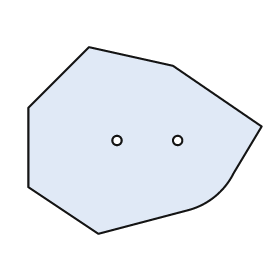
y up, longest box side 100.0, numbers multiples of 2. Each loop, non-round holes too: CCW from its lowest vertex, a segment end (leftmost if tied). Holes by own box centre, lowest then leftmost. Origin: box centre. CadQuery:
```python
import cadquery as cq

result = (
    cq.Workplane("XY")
    .moveTo(-20.0, -40.0)
    .lineTo(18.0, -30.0)
    .threePointArc((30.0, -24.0), (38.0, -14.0))
    .lineTo(50.0, 6.0)
    .lineTo(12.0, 32.0)
    .lineTo(-24.0, 40.0)
    .lineTo(-50.0, 14.0)
    .lineTo(-50.0, -20.0)
    .close()
    .moveTo(-12.0, 0.0)
    .circle(2.0)
    .moveTo(14.0, 0.0)
    .circle(2.0)
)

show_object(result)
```